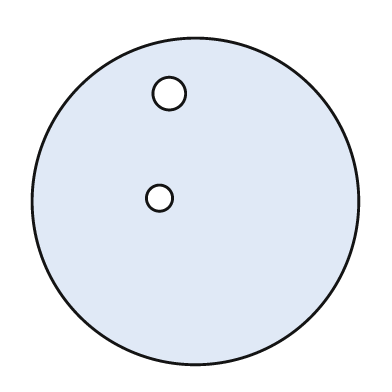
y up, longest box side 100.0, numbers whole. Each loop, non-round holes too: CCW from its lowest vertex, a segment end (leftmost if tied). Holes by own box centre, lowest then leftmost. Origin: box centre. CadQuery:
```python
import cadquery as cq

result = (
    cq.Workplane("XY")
    .moveTo(0.0, 0.0)
    .circle(50.0)
    .moveTo(-11.0, 1.0)
    .circle(4.0)
    .moveTo(-8.0, 33.0)
    .circle(5.0)
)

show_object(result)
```